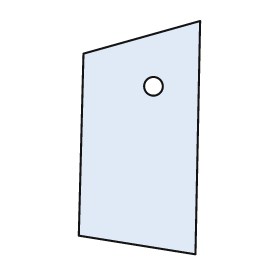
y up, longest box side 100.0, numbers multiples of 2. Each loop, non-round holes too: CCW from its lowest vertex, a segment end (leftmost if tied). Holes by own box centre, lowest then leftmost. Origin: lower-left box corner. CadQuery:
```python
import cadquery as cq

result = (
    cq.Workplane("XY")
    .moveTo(50.0, 0.0)
    .lineTo(52.0, 100.0)
    .lineTo(2.0, 86.0)
    .lineTo(0.0, 8.0)
    .close()
    .moveTo(32.0, 72.0)
    .circle(4.0)
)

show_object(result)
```